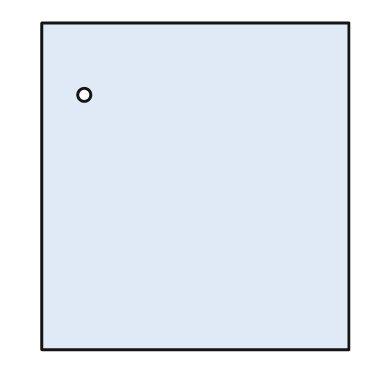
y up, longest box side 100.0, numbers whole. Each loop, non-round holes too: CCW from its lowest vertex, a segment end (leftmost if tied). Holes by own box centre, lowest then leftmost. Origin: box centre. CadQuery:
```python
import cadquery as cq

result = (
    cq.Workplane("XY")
    .moveTo(-47.0, -50.0)
    .lineTo(47.0, -50.0)
    .lineTo(47.0, 50.0)
    .lineTo(-47.0, 50.0)
    .close()
    .moveTo(-34.0, 28.0)
    .circle(2.0)
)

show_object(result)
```